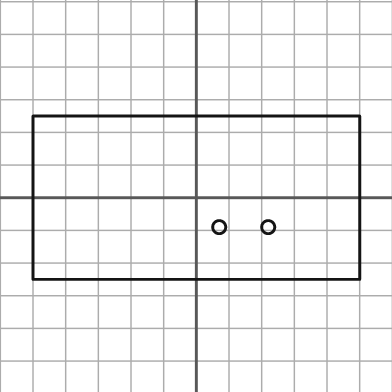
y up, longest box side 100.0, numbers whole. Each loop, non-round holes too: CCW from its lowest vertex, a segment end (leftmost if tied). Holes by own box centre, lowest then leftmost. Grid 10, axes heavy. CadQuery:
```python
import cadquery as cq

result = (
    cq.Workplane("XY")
    .moveTo(-50.0, -25.0)
    .lineTo(50.0, -25.0)
    .lineTo(50.0, 25.0)
    .lineTo(-50.0, 25.0)
    .close()
    .moveTo(7.0, -9.0)
    .circle(2.0)
    .moveTo(22.0, -9.0)
    .circle(2.0)
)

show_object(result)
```